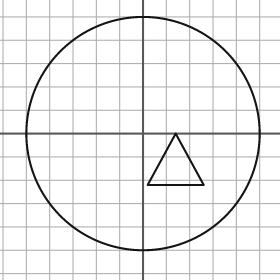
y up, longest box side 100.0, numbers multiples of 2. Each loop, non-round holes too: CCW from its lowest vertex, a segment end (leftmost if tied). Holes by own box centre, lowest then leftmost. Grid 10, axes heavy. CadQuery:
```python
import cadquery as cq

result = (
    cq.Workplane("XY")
    .moveTo(0.0, 0.0)
    .circle(50.0)
    .moveTo(2.0, -22.0)
    .lineTo(26.0, -22.0)
    .lineTo(14.0, 0.0)
    .close()
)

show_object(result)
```